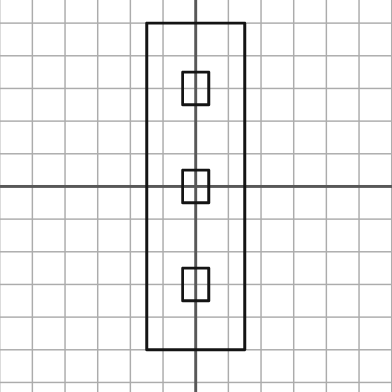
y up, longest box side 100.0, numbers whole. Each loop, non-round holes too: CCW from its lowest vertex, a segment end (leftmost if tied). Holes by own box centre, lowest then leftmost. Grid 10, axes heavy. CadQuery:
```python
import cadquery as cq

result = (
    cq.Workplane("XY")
    .moveTo(-15.0, -50.0)
    .lineTo(15.0, -50.0)
    .lineTo(15.0, 50.0)
    .lineTo(-15.0, 50.0)
    .close()
    .moveTo(-4.0, -35.0)
    .lineTo(4.0, -35.0)
    .lineTo(4.0, -25.0)
    .lineTo(-4.0, -25.0)
    .close()
    .moveTo(-4.0, -5.0)
    .lineTo(4.0, -5.0)
    .lineTo(4.0, 5.0)
    .lineTo(-4.0, 5.0)
    .close()
    .moveTo(-4.0, 25.0)
    .lineTo(4.0, 25.0)
    .lineTo(4.0, 35.0)
    .lineTo(-4.0, 35.0)
    .close()
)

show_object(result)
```